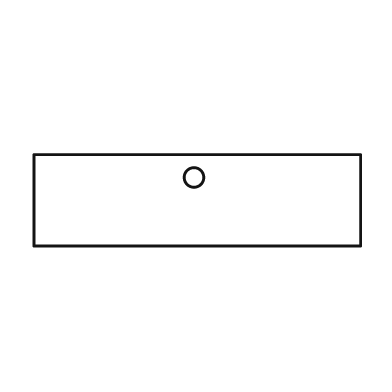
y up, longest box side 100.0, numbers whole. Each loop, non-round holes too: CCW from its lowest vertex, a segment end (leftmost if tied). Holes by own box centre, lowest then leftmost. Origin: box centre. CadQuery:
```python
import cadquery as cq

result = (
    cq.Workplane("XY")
    .moveTo(-50.0, -14.0)
    .lineTo(50.0, -14.0)
    .lineTo(50.0, 14.0)
    .lineTo(-50.0, 14.0)
    .close()
    .moveTo(-1.0, 7.0)
    .circle(3.0)
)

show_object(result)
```